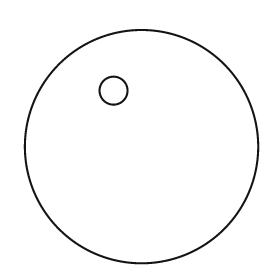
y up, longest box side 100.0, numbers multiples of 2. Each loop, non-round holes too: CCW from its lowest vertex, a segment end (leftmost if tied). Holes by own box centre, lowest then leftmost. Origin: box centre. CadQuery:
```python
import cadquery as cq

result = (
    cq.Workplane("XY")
    .moveTo(0.0, 0.0)
    .circle(50.0)
    .moveTo(-12.0, 24.0)
    .circle(6.0)
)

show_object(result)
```